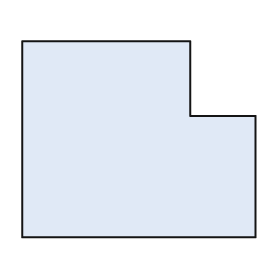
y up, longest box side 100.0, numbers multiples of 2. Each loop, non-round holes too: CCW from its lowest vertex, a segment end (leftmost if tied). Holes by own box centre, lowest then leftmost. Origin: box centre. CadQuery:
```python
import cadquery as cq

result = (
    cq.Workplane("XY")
    .moveTo(-50.0, -42.0)
    .lineTo(50.0, -42.0)
    .lineTo(50.0, 10.0)
    .lineTo(22.0, 10.0)
    .lineTo(22.0, 42.0)
    .lineTo(-50.0, 42.0)
    .close()
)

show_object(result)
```